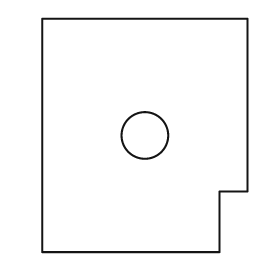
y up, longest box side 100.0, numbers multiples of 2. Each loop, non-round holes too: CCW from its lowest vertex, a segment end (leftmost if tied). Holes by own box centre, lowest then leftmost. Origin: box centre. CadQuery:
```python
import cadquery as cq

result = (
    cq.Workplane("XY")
    .moveTo(-44.0, -50.0)
    .lineTo(32.0, -50.0)
    .lineTo(32.0, -24.0)
    .lineTo(44.0, -24.0)
    .lineTo(44.0, 50.0)
    .lineTo(-44.0, 50.0)
    .close()
    .moveTo(0.0, 0.0)
    .circle(10.0)
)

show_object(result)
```